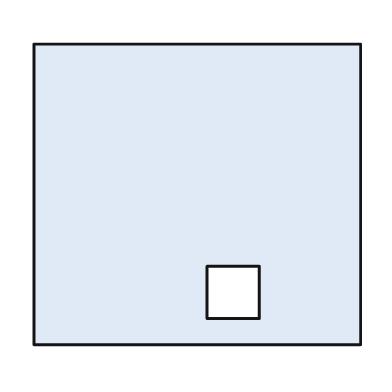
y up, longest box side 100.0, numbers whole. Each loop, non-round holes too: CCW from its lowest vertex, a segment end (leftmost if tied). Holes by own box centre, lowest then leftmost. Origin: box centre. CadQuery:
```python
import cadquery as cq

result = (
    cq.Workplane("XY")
    .moveTo(-50.0, -46.0)
    .lineTo(50.0, -46.0)
    .lineTo(50.0, 46.0)
    .lineTo(-50.0, 46.0)
    .close()
    .moveTo(3.0, -38.0)
    .lineTo(19.0, -38.0)
    .lineTo(19.0, -22.0)
    .lineTo(3.0, -22.0)
    .close()
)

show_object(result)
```